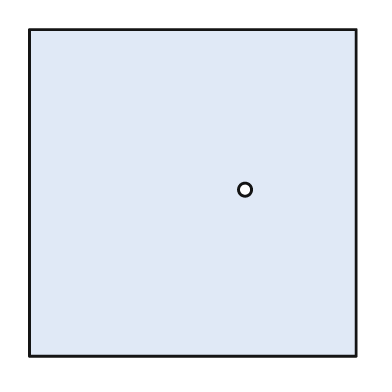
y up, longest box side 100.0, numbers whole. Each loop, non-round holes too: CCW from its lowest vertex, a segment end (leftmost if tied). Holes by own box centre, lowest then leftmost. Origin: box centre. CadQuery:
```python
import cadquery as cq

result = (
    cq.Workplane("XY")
    .moveTo(-50.0, -50.0)
    .lineTo(50.0, -50.0)
    .lineTo(50.0, 50.0)
    .lineTo(-50.0, 50.0)
    .close()
    .moveTo(16.0, 1.0)
    .circle(2.0)
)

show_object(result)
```